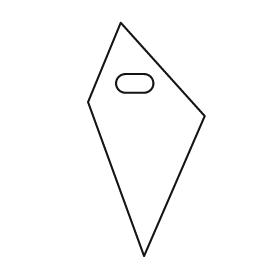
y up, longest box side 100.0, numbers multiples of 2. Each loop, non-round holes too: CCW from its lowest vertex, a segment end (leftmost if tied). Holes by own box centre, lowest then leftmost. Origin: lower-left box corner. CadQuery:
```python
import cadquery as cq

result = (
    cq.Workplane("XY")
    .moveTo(24.0, 0.0)
    .lineTo(50.0, 60.0)
    .lineTo(14.0, 100.0)
    .lineTo(0.0, 66.0)
    .close()
    .moveTo(16.0, 70.0)
    .lineTo(24.0, 70.0)
    .threePointArc((28.0, 74.0), (24.0, 78.0))
    .lineTo(16.0, 78.0)
    .threePointArc((12.0, 74.0), (16.0, 70.0))
    .close()
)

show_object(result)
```